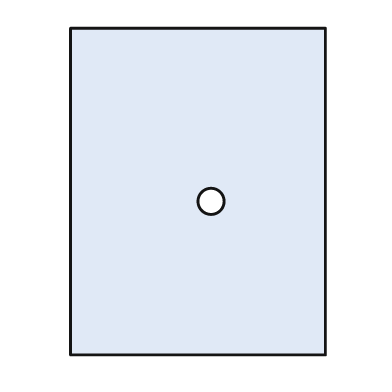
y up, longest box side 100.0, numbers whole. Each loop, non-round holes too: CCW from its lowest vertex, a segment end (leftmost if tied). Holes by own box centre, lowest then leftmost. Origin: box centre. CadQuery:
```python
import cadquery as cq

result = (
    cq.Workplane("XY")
    .moveTo(-39.0, -50.0)
    .lineTo(39.0, -50.0)
    .lineTo(39.0, 50.0)
    .lineTo(-39.0, 50.0)
    .close()
    .moveTo(4.0, -3.0)
    .circle(4.0)
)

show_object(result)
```